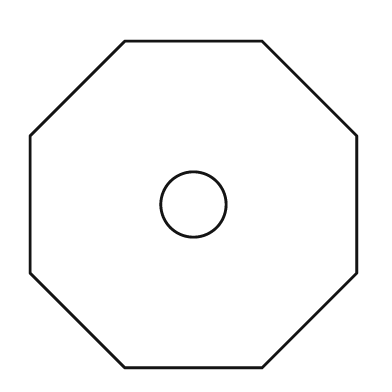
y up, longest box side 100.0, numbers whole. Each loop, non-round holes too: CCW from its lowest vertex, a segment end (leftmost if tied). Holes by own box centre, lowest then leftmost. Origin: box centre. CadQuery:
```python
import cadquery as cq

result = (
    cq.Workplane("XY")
    .moveTo(-21.0, -50.0)
    .lineTo(21.0, -50.0)
    .lineTo(50.0, -21.0)
    .lineTo(50.0, 21.0)
    .lineTo(21.0, 50.0)
    .lineTo(-21.0, 50.0)
    .lineTo(-50.0, 21.0)
    .lineTo(-50.0, -21.0)
    .close()
    .moveTo(0.0, 0.0)
    .circle(10.0)
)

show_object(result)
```